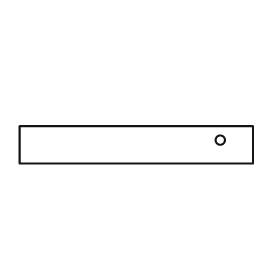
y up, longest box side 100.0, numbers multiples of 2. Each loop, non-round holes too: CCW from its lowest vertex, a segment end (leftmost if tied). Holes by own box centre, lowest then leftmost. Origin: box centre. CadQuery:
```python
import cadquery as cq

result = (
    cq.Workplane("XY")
    .moveTo(-50.0, -8.0)
    .lineTo(50.0, -8.0)
    .lineTo(50.0, 8.0)
    .lineTo(-50.0, 8.0)
    .close()
    .moveTo(36.0, 2.0)
    .circle(2.0)
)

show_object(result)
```